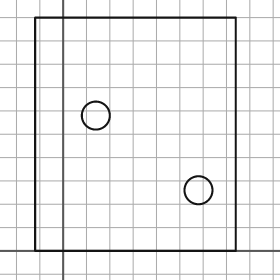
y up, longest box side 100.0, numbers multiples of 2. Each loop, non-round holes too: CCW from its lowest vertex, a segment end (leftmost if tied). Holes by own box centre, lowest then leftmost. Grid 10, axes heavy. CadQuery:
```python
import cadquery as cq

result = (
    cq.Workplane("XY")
    .moveTo(-12.0, 0.0)
    .lineTo(74.0, 0.0)
    .lineTo(74.0, 100.0)
    .lineTo(-12.0, 100.0)
    .close()
    .moveTo(58.0, 26.0)
    .circle(6.0)
    .moveTo(14.0, 58.0)
    .circle(6.0)
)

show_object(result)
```